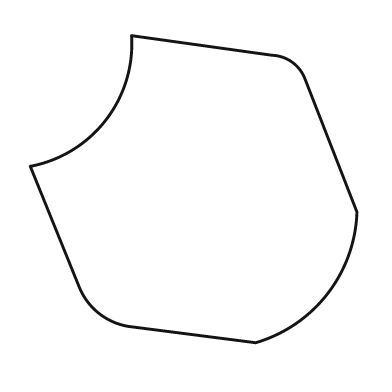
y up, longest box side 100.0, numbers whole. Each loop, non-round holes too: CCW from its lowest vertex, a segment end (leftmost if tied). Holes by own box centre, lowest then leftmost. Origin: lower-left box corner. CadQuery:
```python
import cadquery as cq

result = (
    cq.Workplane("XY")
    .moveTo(69.0, 0.0)
    .threePointArc((91.0, 15.0), (100.0, 40.0))
    .lineTo(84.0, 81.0)
    .threePointArc((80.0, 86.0), (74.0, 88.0))
    .lineTo(31.0, 94.0)
    .threePointArc((23.0, 68.0), (0.0, 54.0))
    .lineTo(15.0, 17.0)
    .threePointArc((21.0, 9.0), (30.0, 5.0))
    .close()
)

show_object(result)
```